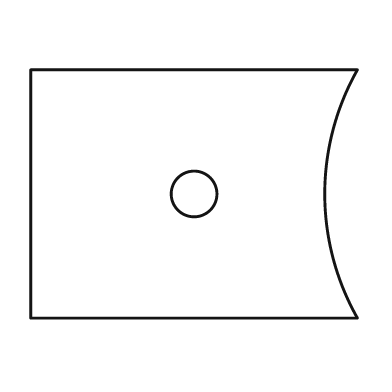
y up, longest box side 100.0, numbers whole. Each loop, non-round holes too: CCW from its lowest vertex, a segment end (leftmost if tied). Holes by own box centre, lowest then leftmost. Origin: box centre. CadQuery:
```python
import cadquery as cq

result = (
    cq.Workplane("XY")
    .moveTo(-50.0, -38.0)
    .lineTo(50.0, -38.0)
    .threePointArc((40.0, 0.0), (50.0, 38.0))
    .lineTo(-50.0, 38.0)
    .close()
    .moveTo(0.0, 0.0)
    .circle(7.0)
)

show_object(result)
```